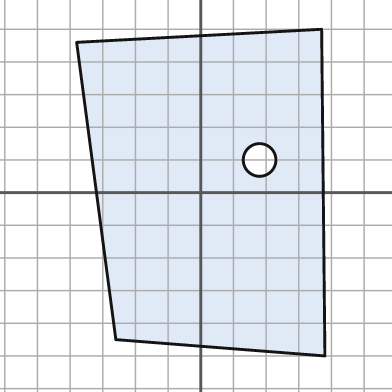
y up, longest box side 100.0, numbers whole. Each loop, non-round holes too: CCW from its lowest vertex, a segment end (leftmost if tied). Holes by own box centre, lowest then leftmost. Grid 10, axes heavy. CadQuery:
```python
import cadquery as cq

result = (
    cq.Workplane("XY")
    .moveTo(38.0, -50.0)
    .lineTo(37.0, 50.0)
    .lineTo(-38.0, 46.0)
    .lineTo(-26.0, -45.0)
    .close()
    .moveTo(18.0, 10.0)
    .circle(5.0)
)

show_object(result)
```